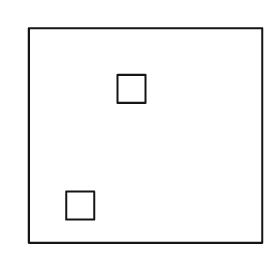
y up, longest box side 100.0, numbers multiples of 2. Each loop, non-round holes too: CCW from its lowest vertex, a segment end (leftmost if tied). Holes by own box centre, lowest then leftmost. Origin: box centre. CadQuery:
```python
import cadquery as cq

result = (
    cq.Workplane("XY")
    .moveTo(-50.0, -46.0)
    .lineTo(50.0, -46.0)
    .lineTo(50.0, 46.0)
    .lineTo(-50.0, 46.0)
    .close()
    .moveTo(-34.0, -36.0)
    .lineTo(-22.0, -36.0)
    .lineTo(-22.0, -24.0)
    .lineTo(-34.0, -24.0)
    .close()
    .moveTo(-12.0, 14.0)
    .lineTo(0.0, 14.0)
    .lineTo(0.0, 26.0)
    .lineTo(-12.0, 26.0)
    .close()
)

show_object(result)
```